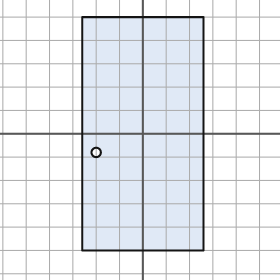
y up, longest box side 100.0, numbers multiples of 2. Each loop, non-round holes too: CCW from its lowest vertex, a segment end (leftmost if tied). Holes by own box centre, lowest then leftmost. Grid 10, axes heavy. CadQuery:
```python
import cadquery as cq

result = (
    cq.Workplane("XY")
    .moveTo(-26.0, -50.0)
    .lineTo(26.0, -50.0)
    .lineTo(26.0, 50.0)
    .lineTo(-26.0, 50.0)
    .close()
    .moveTo(-20.0, -8.0)
    .circle(2.0)
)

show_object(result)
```